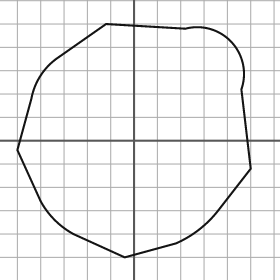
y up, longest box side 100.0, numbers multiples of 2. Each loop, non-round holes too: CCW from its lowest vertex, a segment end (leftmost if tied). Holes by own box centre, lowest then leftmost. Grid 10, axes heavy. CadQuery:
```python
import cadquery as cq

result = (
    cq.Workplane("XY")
    .moveTo(-4.0, -50.0)
    .lineTo(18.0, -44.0)
    .threePointArc((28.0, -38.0), (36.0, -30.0))
    .lineTo(50.0, -12.0)
    .lineTo(46.0, 22.0)
    .threePointArc((42.0, 42.0), (22.0, 48.0))
    .lineTo(-12.0, 50.0)
    .lineTo(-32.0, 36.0)
    .threePointArc((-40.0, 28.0), (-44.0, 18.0))
    .lineTo(-50.0, -4.0)
    .lineTo(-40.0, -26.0)
    .threePointArc((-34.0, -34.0), (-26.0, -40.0))
    .close()
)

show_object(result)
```